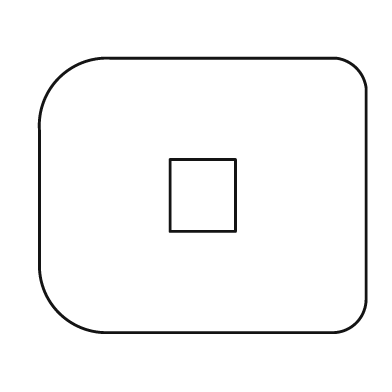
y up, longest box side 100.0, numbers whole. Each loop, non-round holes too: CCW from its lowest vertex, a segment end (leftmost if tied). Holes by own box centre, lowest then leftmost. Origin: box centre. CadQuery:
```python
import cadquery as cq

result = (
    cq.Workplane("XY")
    .moveTo(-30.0, -42.0)
    .lineTo(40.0, -42.0)
    .threePointArc((47.0, -39.0), (50.0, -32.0))
    .lineTo(50.0, 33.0)
    .threePointArc((47.0, 39.0), (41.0, 42.0))
    .lineTo(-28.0, 42.0)
    .threePointArc((-44.0, 36.0), (-50.0, 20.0))
    .lineTo(-50.0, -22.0)
    .threePointArc((-44.0, -36.0), (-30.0, -42.0))
    .close()
    .moveTo(-10.0, -11.0)
    .lineTo(10.0, -11.0)
    .lineTo(10.0, 11.0)
    .lineTo(-10.0, 11.0)
    .close()
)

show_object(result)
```